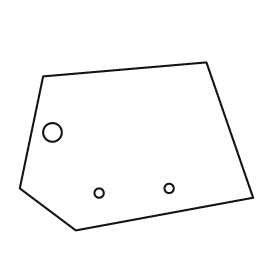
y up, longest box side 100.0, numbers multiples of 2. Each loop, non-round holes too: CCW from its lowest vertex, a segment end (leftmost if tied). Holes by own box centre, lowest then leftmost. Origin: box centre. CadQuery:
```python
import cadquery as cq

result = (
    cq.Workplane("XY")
    .moveTo(-26.0, -36.0)
    .lineTo(50.0, -22.0)
    .lineTo(30.0, 36.0)
    .lineTo(-40.0, 30.0)
    .lineTo(-50.0, -18.0)
    .close()
    .moveTo(-16.0, -20.0)
    .circle(2.0)
    .moveTo(14.0, -18.0)
    .circle(2.0)
    .moveTo(-36.0, 6.0)
    .circle(4.0)
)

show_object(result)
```